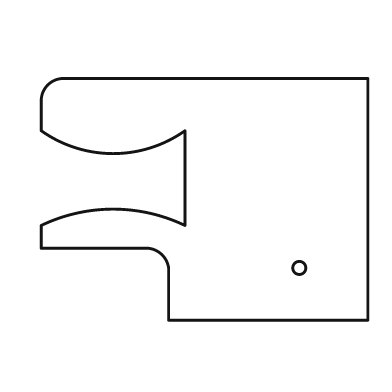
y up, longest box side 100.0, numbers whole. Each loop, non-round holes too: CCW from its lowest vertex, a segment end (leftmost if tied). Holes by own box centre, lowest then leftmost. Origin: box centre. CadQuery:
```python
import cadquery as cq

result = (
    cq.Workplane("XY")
    .moveTo(-11.0, -37.0)
    .lineTo(50.0, -37.0)
    .lineTo(50.0, 37.0)
    .lineTo(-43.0, 37.0)
    .threePointArc((-48.0, 35.0), (-50.0, 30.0))
    .lineTo(-50.0, 21.0)
    .threePointArc((-28.0, 14.0), (-6.0, 21.0))
    .lineTo(-6.0, -8.0)
    .threePointArc((-28.0, -3.0), (-50.0, -8.0))
    .lineTo(-50.0, -15.0)
    .lineTo(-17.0, -15.0)
    .threePointArc((-13.0, -17.0), (-11.0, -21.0))
    .close()
    .moveTo(29.0, -21.0)
    .circle(2.0)
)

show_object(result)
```